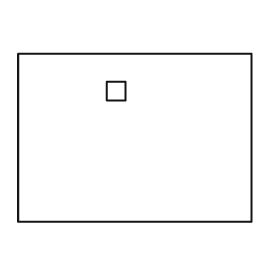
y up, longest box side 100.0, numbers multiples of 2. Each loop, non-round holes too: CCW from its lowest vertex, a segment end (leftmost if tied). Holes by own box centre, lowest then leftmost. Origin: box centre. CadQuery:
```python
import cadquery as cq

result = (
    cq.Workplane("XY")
    .moveTo(-50.0, -36.0)
    .lineTo(50.0, -36.0)
    .lineTo(50.0, 36.0)
    .lineTo(-50.0, 36.0)
    .close()
    .moveTo(-12.0, 16.0)
    .lineTo(-4.0, 16.0)
    .lineTo(-4.0, 24.0)
    .lineTo(-12.0, 24.0)
    .close()
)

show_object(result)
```